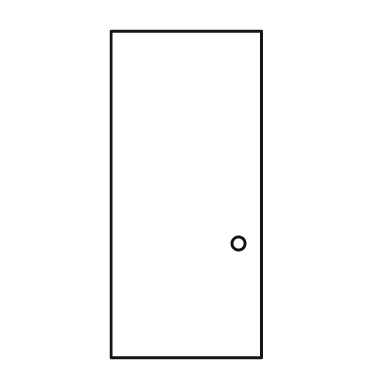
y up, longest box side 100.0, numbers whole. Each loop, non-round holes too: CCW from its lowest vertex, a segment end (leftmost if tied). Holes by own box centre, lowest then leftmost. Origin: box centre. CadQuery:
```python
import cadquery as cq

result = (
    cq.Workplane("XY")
    .moveTo(-23.0, -50.0)
    .lineTo(23.0, -50.0)
    .lineTo(23.0, 50.0)
    .lineTo(-23.0, 50.0)
    .close()
    .moveTo(16.0, -15.0)
    .circle(2.0)
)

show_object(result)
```